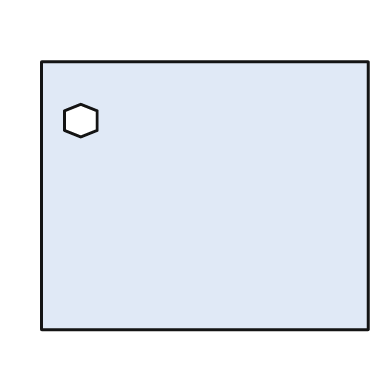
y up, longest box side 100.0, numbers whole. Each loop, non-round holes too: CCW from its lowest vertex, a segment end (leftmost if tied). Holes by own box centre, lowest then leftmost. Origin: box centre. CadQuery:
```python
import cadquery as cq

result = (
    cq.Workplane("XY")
    .moveTo(-50.0, -41.0)
    .lineTo(50.0, -41.0)
    .lineTo(50.0, 41.0)
    .lineTo(-50.0, 41.0)
    .close()
    .moveTo(-38.0, 18.0)
    .lineTo(-33.0, 20.0)
    .lineTo(-33.0, 26.0)
    .lineTo(-38.0, 28.0)
    .lineTo(-43.0, 26.0)
    .lineTo(-43.0, 20.0)
    .close()
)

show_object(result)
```